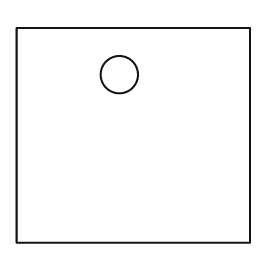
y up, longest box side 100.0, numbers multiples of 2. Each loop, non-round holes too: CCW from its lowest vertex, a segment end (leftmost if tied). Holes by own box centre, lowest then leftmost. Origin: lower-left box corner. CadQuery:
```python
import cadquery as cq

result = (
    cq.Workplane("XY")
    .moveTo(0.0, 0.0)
    .lineTo(100.0, 0.0)
    .lineTo(100.0, 92.0)
    .lineTo(0.0, 92.0)
    .close()
    .moveTo(44.0, 72.0)
    .circle(8.0)
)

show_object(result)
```